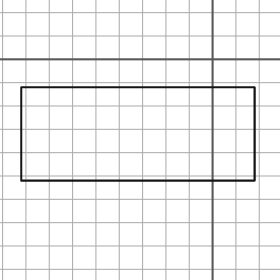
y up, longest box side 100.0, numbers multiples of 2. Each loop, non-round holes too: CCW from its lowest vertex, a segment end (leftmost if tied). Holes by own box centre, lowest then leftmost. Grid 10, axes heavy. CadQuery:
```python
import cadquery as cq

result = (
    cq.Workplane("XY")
    .moveTo(-82.0, -52.0)
    .lineTo(18.0, -52.0)
    .lineTo(18.0, -12.0)
    .lineTo(-82.0, -12.0)
    .close()
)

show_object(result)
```